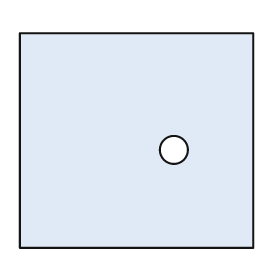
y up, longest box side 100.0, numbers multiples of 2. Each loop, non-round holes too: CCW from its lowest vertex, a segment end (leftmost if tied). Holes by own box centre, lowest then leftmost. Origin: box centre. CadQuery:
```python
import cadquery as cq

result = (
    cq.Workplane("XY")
    .moveTo(-50.0, -46.0)
    .lineTo(50.0, -46.0)
    .lineTo(50.0, 46.0)
    .lineTo(-50.0, 46.0)
    .close()
    .moveTo(16.0, -4.0)
    .circle(6.0)
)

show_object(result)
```